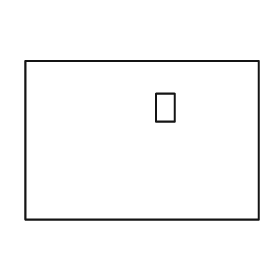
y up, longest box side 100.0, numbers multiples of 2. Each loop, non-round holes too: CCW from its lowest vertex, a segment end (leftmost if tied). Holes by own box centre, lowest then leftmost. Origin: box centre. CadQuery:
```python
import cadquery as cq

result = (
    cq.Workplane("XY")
    .moveTo(-50.0, -34.0)
    .lineTo(50.0, -34.0)
    .lineTo(50.0, 34.0)
    .lineTo(-50.0, 34.0)
    .close()
    .moveTo(6.0, 8.0)
    .lineTo(14.0, 8.0)
    .lineTo(14.0, 20.0)
    .lineTo(6.0, 20.0)
    .close()
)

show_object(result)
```